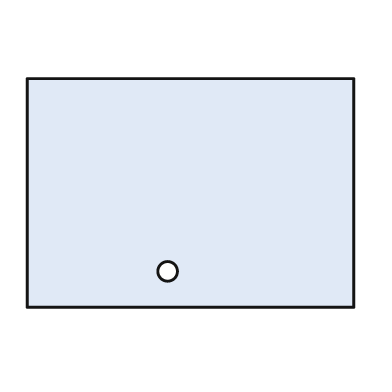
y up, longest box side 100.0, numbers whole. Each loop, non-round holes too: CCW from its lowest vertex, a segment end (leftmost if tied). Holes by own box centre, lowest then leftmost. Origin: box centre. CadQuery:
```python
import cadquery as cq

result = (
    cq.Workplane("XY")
    .moveTo(-50.0, -35.0)
    .lineTo(50.0, -35.0)
    .lineTo(50.0, 35.0)
    .lineTo(-50.0, 35.0)
    .close()
    .moveTo(-7.0, -24.0)
    .circle(3.0)
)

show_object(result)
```